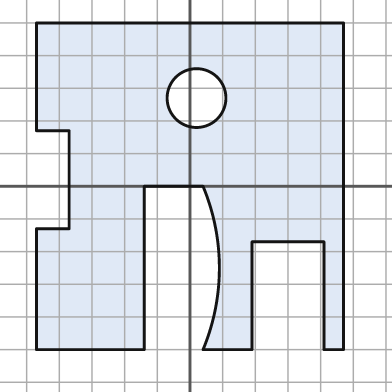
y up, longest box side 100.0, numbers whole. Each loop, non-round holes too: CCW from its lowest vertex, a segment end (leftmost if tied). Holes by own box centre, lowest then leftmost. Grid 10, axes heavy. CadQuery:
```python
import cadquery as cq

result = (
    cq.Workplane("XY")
    .moveTo(-47.0, -50.0)
    .lineTo(-14.0, -50.0)
    .lineTo(-14.0, 0.0)
    .lineTo(4.0, 0.0)
    .threePointArc((9.0, -25.0), (4.0, -50.0))
    .lineTo(19.0, -50.0)
    .lineTo(19.0, -17.0)
    .lineTo(41.0, -17.0)
    .lineTo(41.0, -50.0)
    .lineTo(47.0, -50.0)
    .lineTo(47.0, 50.0)
    .lineTo(-47.0, 50.0)
    .lineTo(-47.0, 17.0)
    .lineTo(-37.0, 17.0)
    .lineTo(-37.0, -13.0)
    .lineTo(-47.0, -13.0)
    .close()
    .moveTo(2.0, 27.0)
    .circle(9.0)
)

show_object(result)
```